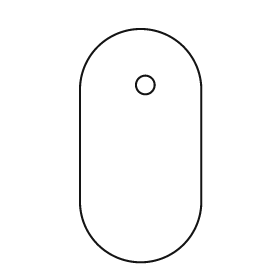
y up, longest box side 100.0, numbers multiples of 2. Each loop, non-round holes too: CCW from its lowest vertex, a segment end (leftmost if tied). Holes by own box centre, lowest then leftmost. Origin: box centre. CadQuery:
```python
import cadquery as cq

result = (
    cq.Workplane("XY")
    .moveTo(-26.0, -24.0)
    .threePointArc((0.0, -50.0), (26.0, -24.0))
    .lineTo(26.0, 24.0)
    .threePointArc((0.0, 50.0), (-26.0, 24.0))
    .close()
    .moveTo(2.0, 26.0)
    .circle(4.0)
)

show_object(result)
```